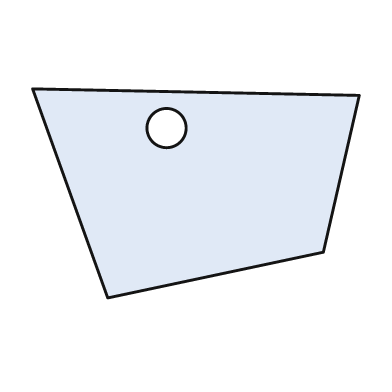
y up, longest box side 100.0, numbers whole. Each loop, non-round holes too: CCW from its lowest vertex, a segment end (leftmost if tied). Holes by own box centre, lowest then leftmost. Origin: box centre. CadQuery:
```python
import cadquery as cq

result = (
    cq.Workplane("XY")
    .moveTo(-27.0, -32.0)
    .lineTo(39.0, -18.0)
    .lineTo(50.0, 30.0)
    .lineTo(-50.0, 32.0)
    .close()
    .moveTo(-9.0, 20.0)
    .circle(6.0)
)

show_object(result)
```